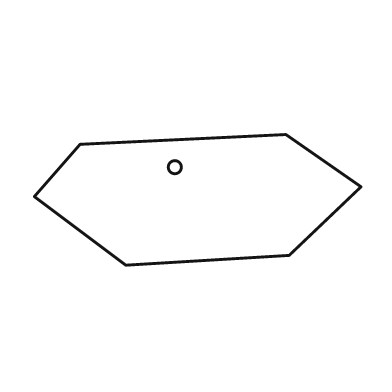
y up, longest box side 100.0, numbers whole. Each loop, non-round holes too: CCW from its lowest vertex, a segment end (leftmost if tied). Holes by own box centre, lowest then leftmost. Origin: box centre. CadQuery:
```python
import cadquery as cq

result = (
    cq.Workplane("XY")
    .moveTo(-22.0, -20.0)
    .lineTo(28.0, -17.0)
    .lineTo(50.0, 4.0)
    .lineTo(27.0, 20.0)
    .lineTo(-36.0, 17.0)
    .lineTo(-50.0, 1.0)
    .close()
    .moveTo(-7.0, 10.0)
    .circle(2.0)
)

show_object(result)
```